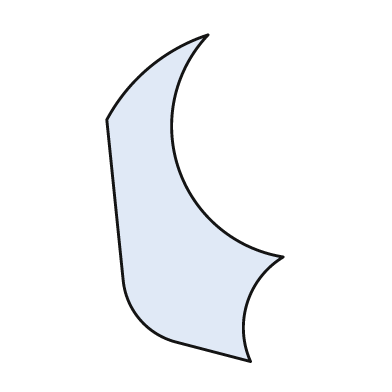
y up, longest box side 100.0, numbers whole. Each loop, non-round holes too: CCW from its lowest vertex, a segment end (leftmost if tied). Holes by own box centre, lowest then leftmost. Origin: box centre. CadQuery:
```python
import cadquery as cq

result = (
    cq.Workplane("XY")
    .moveTo(17.0, -50.0)
    .threePointArc((16.0, -32.0), (27.0, -18.0))
    .threePointArc((-5.0, 9.0), (4.0, 50.0))
    .threePointArc((-14.0, 40.0), (-27.0, 24.0))
    .lineTo(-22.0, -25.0)
    .threePointArc((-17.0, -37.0), (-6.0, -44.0))
    .close()
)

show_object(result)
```